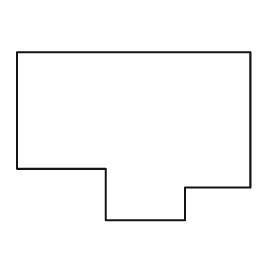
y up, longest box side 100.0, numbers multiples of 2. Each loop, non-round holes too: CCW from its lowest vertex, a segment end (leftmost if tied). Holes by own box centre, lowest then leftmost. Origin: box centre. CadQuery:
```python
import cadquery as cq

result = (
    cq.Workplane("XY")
    .moveTo(-12.0, -36.0)
    .lineTo(22.0, -36.0)
    .lineTo(22.0, -22.0)
    .lineTo(50.0, -22.0)
    .lineTo(50.0, 36.0)
    .lineTo(-50.0, 36.0)
    .lineTo(-50.0, -14.0)
    .lineTo(-12.0, -14.0)
    .close()
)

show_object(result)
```